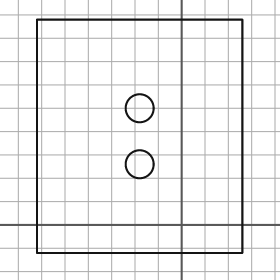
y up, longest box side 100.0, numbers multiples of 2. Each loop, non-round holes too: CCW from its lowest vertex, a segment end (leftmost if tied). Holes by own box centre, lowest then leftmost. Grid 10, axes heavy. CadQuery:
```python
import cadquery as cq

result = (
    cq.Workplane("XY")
    .moveTo(-62.0, -12.0)
    .lineTo(26.0, -12.0)
    .lineTo(26.0, 88.0)
    .lineTo(-62.0, 88.0)
    .close()
    .moveTo(-18.0, 26.0)
    .circle(6.0)
    .moveTo(-18.0, 50.0)
    .circle(6.0)
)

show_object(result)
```